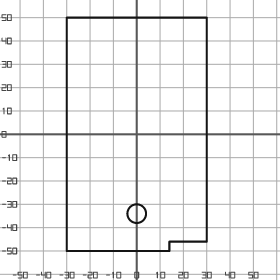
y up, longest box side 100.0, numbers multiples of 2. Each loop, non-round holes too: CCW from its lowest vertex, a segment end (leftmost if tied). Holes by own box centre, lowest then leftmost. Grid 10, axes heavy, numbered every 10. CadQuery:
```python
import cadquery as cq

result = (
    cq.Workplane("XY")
    .moveTo(-30.0, -50.0)
    .lineTo(14.0, -50.0)
    .lineTo(14.0, -46.0)
    .lineTo(30.0, -46.0)
    .lineTo(30.0, 50.0)
    .lineTo(-30.0, 50.0)
    .close()
    .moveTo(0.0, -34.0)
    .circle(4.0)
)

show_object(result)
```